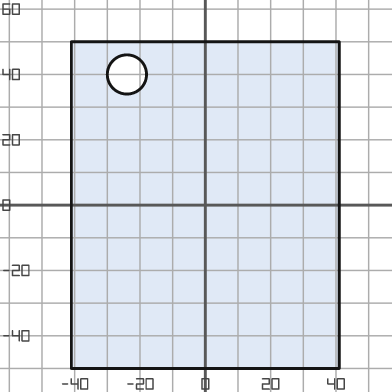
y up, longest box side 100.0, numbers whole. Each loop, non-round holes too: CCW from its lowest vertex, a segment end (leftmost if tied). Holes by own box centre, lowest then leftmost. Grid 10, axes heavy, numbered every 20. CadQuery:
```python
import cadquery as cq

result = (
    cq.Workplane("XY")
    .moveTo(-41.0, -50.0)
    .lineTo(41.0, -50.0)
    .lineTo(41.0, 50.0)
    .lineTo(-41.0, 50.0)
    .close()
    .moveTo(-24.0, 40.0)
    .circle(6.0)
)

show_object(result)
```